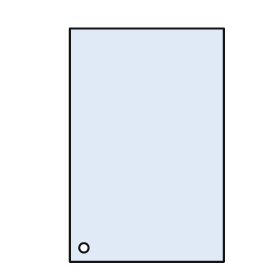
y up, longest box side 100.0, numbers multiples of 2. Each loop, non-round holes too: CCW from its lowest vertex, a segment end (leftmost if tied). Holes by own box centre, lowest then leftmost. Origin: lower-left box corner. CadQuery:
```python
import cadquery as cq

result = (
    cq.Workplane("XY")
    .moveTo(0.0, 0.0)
    .lineTo(66.0, 0.0)
    .lineTo(66.0, 100.0)
    .lineTo(0.0, 100.0)
    .close()
    .moveTo(6.0, 6.0)
    .circle(2.0)
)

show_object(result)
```